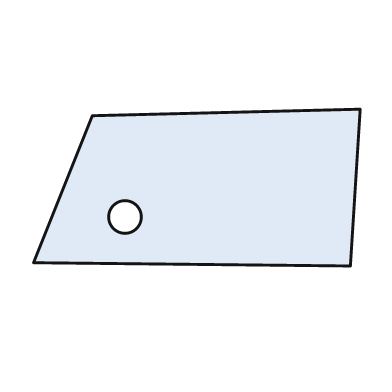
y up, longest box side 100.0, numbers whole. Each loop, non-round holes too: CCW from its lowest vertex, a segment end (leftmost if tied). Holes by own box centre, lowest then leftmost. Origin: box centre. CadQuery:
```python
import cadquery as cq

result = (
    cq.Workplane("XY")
    .moveTo(47.0, -24.0)
    .lineTo(50.0, 24.0)
    .lineTo(-32.0, 22.0)
    .lineTo(-50.0, -23.0)
    .close()
    .moveTo(-22.0, -9.0)
    .circle(5.0)
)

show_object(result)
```